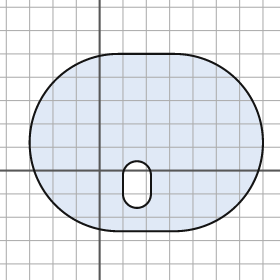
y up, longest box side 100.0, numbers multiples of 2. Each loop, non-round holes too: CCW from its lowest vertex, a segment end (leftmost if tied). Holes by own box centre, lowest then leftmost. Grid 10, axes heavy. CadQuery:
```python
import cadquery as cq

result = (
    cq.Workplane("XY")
    .moveTo(8.0, -26.0)
    .lineTo(32.0, -26.0)
    .threePointArc((70.0, 12.0), (32.0, 50.0))
    .lineTo(8.0, 50.0)
    .threePointArc((-30.0, 12.0), (8.0, -26.0))
    .close()
    .moveTo(10.0, -10.0)
    .threePointArc((16.0, -16.0), (22.0, -10.0))
    .lineTo(22.0, -2.0)
    .threePointArc((16.0, 4.0), (10.0, -2.0))
    .close()
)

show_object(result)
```